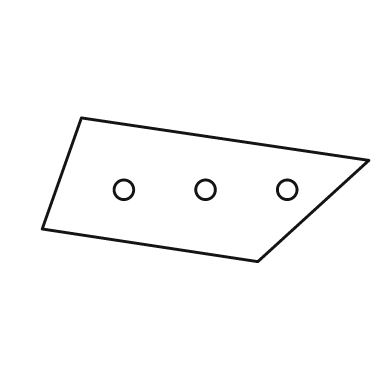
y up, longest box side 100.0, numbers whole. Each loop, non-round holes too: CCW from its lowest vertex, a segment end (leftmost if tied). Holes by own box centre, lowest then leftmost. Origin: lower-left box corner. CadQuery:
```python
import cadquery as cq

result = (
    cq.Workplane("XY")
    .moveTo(66.0, 0.0)
    .lineTo(100.0, 31.0)
    .lineTo(12.0, 44.0)
    .lineTo(0.0, 10.0)
    .close()
    .moveTo(25.0, 22.0)
    .circle(3.0)
    .moveTo(50.0, 22.0)
    .circle(3.0)
    .moveTo(75.0, 22.0)
    .circle(3.0)
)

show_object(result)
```